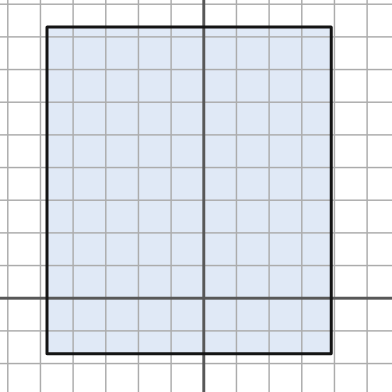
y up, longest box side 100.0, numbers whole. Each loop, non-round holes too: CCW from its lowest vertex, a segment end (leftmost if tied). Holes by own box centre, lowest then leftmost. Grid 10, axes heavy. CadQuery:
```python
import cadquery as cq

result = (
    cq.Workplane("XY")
    .moveTo(-48.0, -17.0)
    .lineTo(39.0, -17.0)
    .lineTo(39.0, 83.0)
    .lineTo(-48.0, 83.0)
    .close()
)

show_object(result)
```